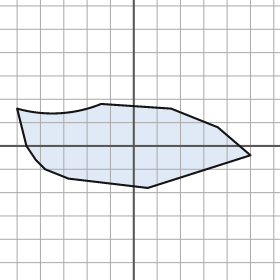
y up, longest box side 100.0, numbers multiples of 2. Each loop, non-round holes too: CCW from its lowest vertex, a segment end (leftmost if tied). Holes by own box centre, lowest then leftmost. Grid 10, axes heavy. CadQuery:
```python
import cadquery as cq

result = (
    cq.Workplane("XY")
    .moveTo(6.0, -18.0)
    .lineTo(50.0, -4.0)
    .lineTo(36.0, 8.0)
    .lineTo(16.0, 16.0)
    .lineTo(-14.0, 18.0)
    .threePointArc((-32.0, 14.0), (-50.0, 16.0))
    .lineTo(-46.0, 0.0)
    .lineTo(-42.0, -6.0)
    .lineTo(-38.0, -10.0)
    .lineTo(-28.0, -14.0)
    .close()
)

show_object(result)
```